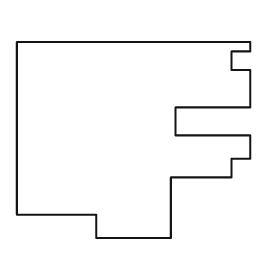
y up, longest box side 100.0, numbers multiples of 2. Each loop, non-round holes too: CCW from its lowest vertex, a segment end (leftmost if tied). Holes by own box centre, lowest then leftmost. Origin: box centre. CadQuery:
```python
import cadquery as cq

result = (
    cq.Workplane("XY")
    .moveTo(-16.0, -42.0)
    .lineTo(16.0, -42.0)
    .lineTo(16.0, -16.0)
    .lineTo(42.0, -16.0)
    .lineTo(42.0, -8.0)
    .lineTo(50.0, -8.0)
    .lineTo(50.0, 2.0)
    .lineTo(18.0, 2.0)
    .lineTo(18.0, 14.0)
    .lineTo(50.0, 14.0)
    .lineTo(50.0, 30.0)
    .lineTo(42.0, 30.0)
    .lineTo(42.0, 38.0)
    .lineTo(50.0, 38.0)
    .lineTo(50.0, 42.0)
    .lineTo(-50.0, 42.0)
    .lineTo(-50.0, -32.0)
    .lineTo(-16.0, -32.0)
    .close()
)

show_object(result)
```